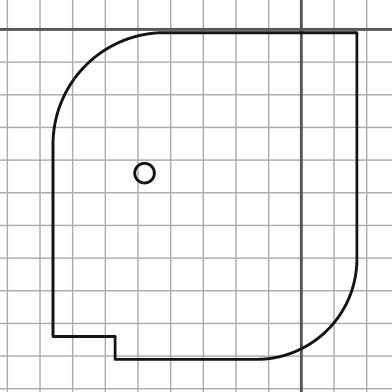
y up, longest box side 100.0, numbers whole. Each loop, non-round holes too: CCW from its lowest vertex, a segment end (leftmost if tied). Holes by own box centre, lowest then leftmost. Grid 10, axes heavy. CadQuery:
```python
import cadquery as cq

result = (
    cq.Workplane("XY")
    .moveTo(-57.0, -101.0)
    .lineTo(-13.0, -101.0)
    .threePointArc((8.0, -92.0), (17.0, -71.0))
    .lineTo(17.0, -1.0)
    .lineTo(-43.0, -1.0)
    .threePointArc((-66.0, -11.0), (-76.0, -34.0))
    .lineTo(-76.0, -94.0)
    .lineTo(-57.0, -94.0)
    .close()
    .moveTo(-48.0, -44.0)
    .circle(3.0)
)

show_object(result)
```